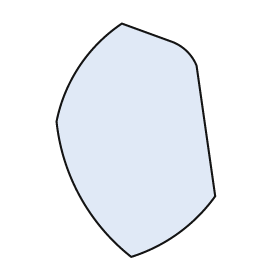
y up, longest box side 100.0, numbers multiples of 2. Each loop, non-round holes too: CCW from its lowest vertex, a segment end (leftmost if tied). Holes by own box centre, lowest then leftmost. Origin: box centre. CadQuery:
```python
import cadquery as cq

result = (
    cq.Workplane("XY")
    .moveTo(-2.0, -50.0)
    .threePointArc((18.0, -40.0), (34.0, -24.0))
    .lineTo(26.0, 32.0)
    .threePointArc((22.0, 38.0), (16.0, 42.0))
    .lineTo(-6.0, 50.0)
    .threePointArc((-24.0, 32.0), (-34.0, 8.0))
    .threePointArc((-24.0, -24.0), (-2.0, -50.0))
    .close()
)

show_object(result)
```